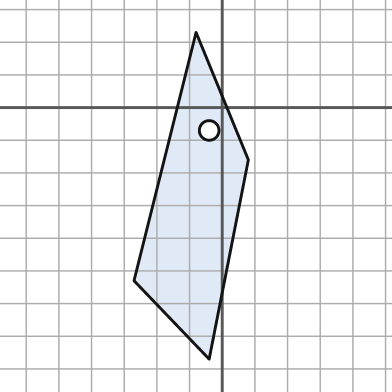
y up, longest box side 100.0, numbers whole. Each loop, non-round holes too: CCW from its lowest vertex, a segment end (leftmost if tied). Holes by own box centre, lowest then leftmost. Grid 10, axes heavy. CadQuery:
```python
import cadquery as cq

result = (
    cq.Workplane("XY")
    .moveTo(-4.0, -77.0)
    .lineTo(8.0, -16.0)
    .lineTo(-8.0, 23.0)
    .lineTo(-27.0, -53.0)
    .close()
    .moveTo(-4.0, -7.0)
    .circle(3.0)
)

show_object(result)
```